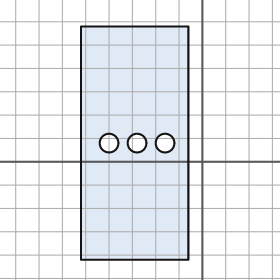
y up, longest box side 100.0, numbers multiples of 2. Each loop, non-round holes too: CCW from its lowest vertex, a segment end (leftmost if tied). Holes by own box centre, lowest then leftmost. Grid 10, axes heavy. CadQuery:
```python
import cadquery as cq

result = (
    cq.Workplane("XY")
    .moveTo(-52.0, -42.0)
    .lineTo(-6.0, -42.0)
    .lineTo(-6.0, 58.0)
    .lineTo(-52.0, 58.0)
    .close()
    .moveTo(-40.0, 8.0)
    .circle(4.0)
    .moveTo(-28.0, 8.0)
    .circle(4.0)
    .moveTo(-16.0, 8.0)
    .circle(4.0)
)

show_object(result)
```